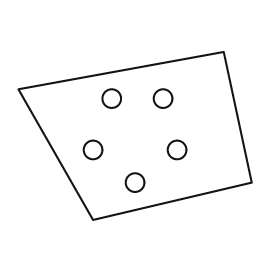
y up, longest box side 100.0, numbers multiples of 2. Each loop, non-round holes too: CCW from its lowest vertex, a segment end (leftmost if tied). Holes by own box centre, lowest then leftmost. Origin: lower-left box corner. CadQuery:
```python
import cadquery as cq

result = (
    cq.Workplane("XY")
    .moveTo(32.0, 0.0)
    .lineTo(100.0, 16.0)
    .lineTo(88.0, 72.0)
    .lineTo(0.0, 56.0)
    .close()
    .moveTo(50.0, 16.0)
    .circle(4.0)
    .moveTo(32.0, 30.0)
    .circle(4.0)
    .moveTo(68.0, 30.0)
    .circle(4.0)
    .moveTo(40.0, 52.0)
    .circle(4.0)
    .moveTo(62.0, 52.0)
    .circle(4.0)
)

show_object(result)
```